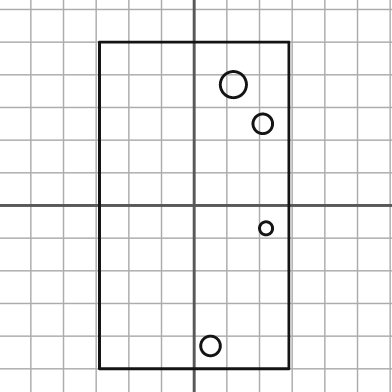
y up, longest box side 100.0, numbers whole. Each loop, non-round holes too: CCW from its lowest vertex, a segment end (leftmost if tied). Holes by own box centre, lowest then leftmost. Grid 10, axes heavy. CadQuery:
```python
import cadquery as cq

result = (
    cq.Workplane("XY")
    .moveTo(-29.0, -50.0)
    .lineTo(29.0, -50.0)
    .lineTo(29.0, 50.0)
    .lineTo(-29.0, 50.0)
    .close()
    .moveTo(5.0, -43.0)
    .circle(3.0)
    .moveTo(22.0, -7.0)
    .circle(2.0)
    .moveTo(21.0, 25.0)
    .circle(3.0)
    .moveTo(12.0, 37.0)
    .circle(4.0)
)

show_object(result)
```